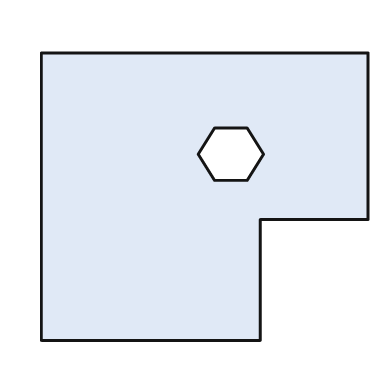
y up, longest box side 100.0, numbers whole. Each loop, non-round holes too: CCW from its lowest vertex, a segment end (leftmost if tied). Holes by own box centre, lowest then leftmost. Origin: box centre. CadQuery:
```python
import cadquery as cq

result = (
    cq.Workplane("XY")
    .moveTo(-50.0, -44.0)
    .lineTo(17.0, -44.0)
    .lineTo(17.0, -7.0)
    .lineTo(50.0, -7.0)
    .lineTo(50.0, 44.0)
    .lineTo(-50.0, 44.0)
    .close()
    .moveTo(3.0, 5.0)
    .lineTo(13.0, 5.0)
    .lineTo(18.0, 13.0)
    .lineTo(13.0, 21.0)
    .lineTo(3.0, 21.0)
    .lineTo(-2.0, 13.0)
    .close()
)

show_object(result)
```